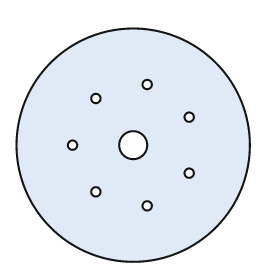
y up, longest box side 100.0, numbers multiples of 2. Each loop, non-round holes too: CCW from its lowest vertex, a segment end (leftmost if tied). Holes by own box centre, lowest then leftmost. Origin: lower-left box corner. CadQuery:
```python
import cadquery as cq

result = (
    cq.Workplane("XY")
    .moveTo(50.0, 50.0)
    .circle(50.0)
    .moveTo(56.0, 24.0)
    .circle(2.0)
    .moveTo(34.0, 30.0)
    .circle(2.0)
    .moveTo(74.0, 38.0)
    .circle(2.0)
    .moveTo(24.0, 50.0)
    .circle(2.0)
    .moveTo(50.0, 50.0)
    .circle(6.0)
    .moveTo(74.0, 62.0)
    .circle(2.0)
    .moveTo(34.0, 70.0)
    .circle(2.0)
    .moveTo(56.0, 76.0)
    .circle(2.0)
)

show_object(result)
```